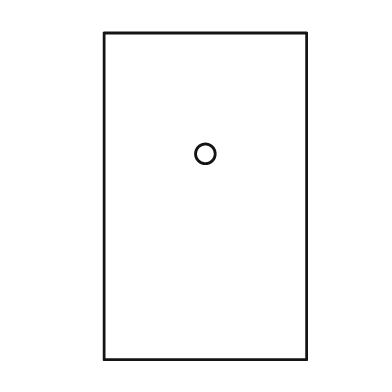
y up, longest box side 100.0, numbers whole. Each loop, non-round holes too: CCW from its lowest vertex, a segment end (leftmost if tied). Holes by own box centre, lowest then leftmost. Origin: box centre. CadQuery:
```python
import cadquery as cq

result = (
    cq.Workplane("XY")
    .moveTo(-31.0, -50.0)
    .lineTo(31.0, -50.0)
    .lineTo(31.0, 50.0)
    .lineTo(-31.0, 50.0)
    .close()
    .moveTo(0.0, 13.0)
    .circle(3.0)
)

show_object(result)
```